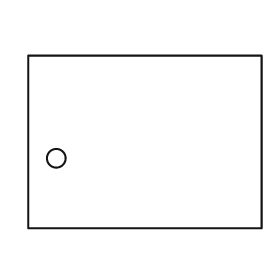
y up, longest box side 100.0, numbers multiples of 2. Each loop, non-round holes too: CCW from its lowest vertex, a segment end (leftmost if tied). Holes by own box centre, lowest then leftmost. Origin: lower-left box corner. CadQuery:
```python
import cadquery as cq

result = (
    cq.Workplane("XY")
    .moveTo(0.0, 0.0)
    .lineTo(100.0, 0.0)
    .lineTo(100.0, 74.0)
    .lineTo(0.0, 74.0)
    .close()
    .moveTo(12.0, 30.0)
    .circle(4.0)
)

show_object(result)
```